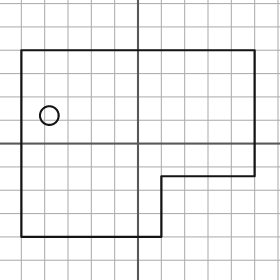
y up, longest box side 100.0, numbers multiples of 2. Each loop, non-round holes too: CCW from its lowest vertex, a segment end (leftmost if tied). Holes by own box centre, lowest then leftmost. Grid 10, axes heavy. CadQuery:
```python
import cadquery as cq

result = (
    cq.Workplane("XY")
    .moveTo(-50.0, -40.0)
    .lineTo(10.0, -40.0)
    .lineTo(10.0, -14.0)
    .lineTo(50.0, -14.0)
    .lineTo(50.0, 40.0)
    .lineTo(-50.0, 40.0)
    .close()
    .moveTo(-38.0, 12.0)
    .circle(4.0)
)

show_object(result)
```